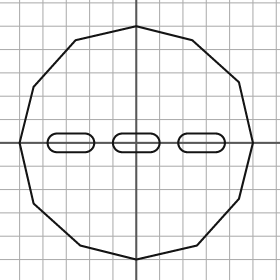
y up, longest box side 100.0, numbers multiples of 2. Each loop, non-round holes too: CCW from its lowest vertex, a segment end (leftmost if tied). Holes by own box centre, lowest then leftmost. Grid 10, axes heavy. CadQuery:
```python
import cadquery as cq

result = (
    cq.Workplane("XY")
    .moveTo(0.0, -50.0)
    .lineTo(26.0, -44.0)
    .lineTo(44.0, -24.0)
    .lineTo(50.0, 0.0)
    .lineTo(44.0, 26.0)
    .lineTo(24.0, 44.0)
    .lineTo(0.0, 50.0)
    .lineTo(-26.0, 44.0)
    .lineTo(-44.0, 24.0)
    .lineTo(-50.0, 0.0)
    .lineTo(-44.0, -26.0)
    .lineTo(-24.0, -44.0)
    .close()
    .moveTo(-34.0, -4.0)
    .lineTo(-22.0, -4.0)
    .threePointArc((-18.0, 0.0), (-22.0, 4.0))
    .lineTo(-34.0, 4.0)
    .threePointArc((-38.0, 0.0), (-34.0, -4.0))
    .close()
    .moveTo(-6.0, -4.0)
    .lineTo(6.0, -4.0)
    .threePointArc((10.0, 0.0), (6.0, 4.0))
    .lineTo(-6.0, 4.0)
    .threePointArc((-10.0, 0.0), (-6.0, -4.0))
    .close()
    .moveTo(22.0, -4.0)
    .lineTo(34.0, -4.0)
    .threePointArc((38.0, 0.0), (34.0, 4.0))
    .lineTo(22.0, 4.0)
    .threePointArc((18.0, 0.0), (22.0, -4.0))
    .close()
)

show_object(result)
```